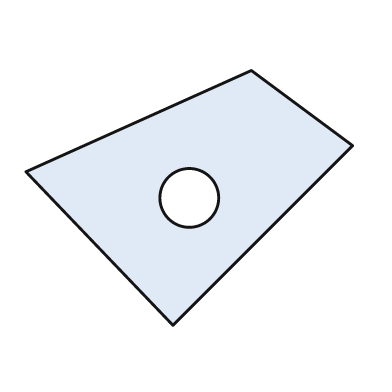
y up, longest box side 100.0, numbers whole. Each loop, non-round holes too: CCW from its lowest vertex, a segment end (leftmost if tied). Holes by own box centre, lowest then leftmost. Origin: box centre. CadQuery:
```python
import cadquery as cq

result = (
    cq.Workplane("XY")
    .moveTo(-5.0, -39.0)
    .lineTo(50.0, 16.0)
    .lineTo(19.0, 39.0)
    .lineTo(-50.0, 8.0)
    .close()
    .moveTo(0.0, 0.0)
    .circle(9.0)
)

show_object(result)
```